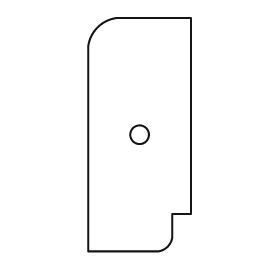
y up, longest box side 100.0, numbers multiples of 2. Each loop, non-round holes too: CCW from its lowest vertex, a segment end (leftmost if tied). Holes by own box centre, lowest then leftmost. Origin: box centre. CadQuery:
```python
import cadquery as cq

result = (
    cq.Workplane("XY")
    .moveTo(-22.0, -50.0)
    .lineTo(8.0, -50.0)
    .threePointArc((12.0, -48.0), (14.0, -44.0))
    .lineTo(14.0, -34.0)
    .lineTo(22.0, -34.0)
    .lineTo(22.0, 50.0)
    .lineTo(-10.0, 50.0)
    .threePointArc((-18.0, 46.0), (-22.0, 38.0))
    .close()
    .moveTo(0.0, 0.0)
    .circle(4.0)
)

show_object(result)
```